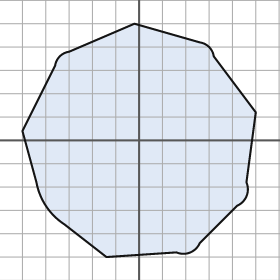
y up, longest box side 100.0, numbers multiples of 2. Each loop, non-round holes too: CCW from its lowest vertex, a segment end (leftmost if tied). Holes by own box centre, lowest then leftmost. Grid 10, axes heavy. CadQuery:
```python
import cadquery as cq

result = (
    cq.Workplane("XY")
    .moveTo(-14.0, -50.0)
    .lineTo(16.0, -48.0)
    .threePointArc((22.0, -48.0), (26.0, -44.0))
    .lineTo(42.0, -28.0)
    .threePointArc((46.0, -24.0), (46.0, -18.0))
    .lineTo(50.0, 12.0)
    .lineTo(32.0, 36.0)
    .threePointArc((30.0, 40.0), (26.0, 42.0))
    .lineTo(-2.0, 50.0)
    .lineTo(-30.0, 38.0)
    .threePointArc((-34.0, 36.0), (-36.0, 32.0))
    .lineTo(-50.0, 4.0)
    .lineTo(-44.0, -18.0)
    .threePointArc((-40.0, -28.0), (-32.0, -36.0))
    .close()
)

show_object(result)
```